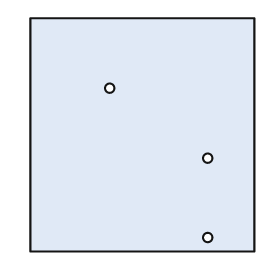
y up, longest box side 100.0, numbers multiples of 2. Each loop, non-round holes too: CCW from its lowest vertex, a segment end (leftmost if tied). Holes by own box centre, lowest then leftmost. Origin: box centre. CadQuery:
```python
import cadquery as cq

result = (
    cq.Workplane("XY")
    .moveTo(-48.0, -50.0)
    .lineTo(48.0, -50.0)
    .lineTo(48.0, 50.0)
    .lineTo(-48.0, 50.0)
    .close()
    .moveTo(28.0, -44.0)
    .circle(2.0)
    .moveTo(28.0, -10.0)
    .circle(2.0)
    .moveTo(-14.0, 20.0)
    .circle(2.0)
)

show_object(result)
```